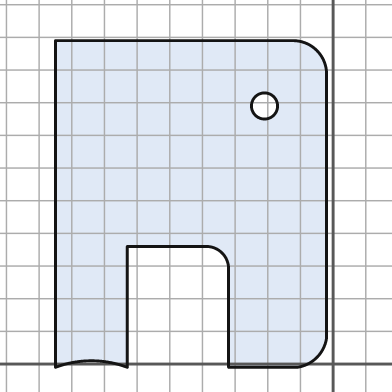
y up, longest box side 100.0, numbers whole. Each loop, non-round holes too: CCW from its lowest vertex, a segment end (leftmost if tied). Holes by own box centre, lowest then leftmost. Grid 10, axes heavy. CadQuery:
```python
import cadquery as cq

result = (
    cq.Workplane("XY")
    .moveTo(-85.0, -1.0)
    .threePointArc((-74.0, 1.0), (-63.0, -1.0))
    .lineTo(-63.0, 36.0)
    .lineTo(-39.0, 36.0)
    .threePointArc((-34.0, 34.0), (-32.0, 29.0))
    .lineTo(-32.0, -1.0)
    .lineTo(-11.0, -1.0)
    .threePointArc((-5.0, 2.0), (-2.0, 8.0))
    .lineTo(-2.0, 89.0)
    .threePointArc((-5.0, 96.0), (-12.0, 99.0))
    .lineTo(-85.0, 99.0)
    .close()
    .moveTo(-21.0, 79.0)
    .circle(4.0)
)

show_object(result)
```